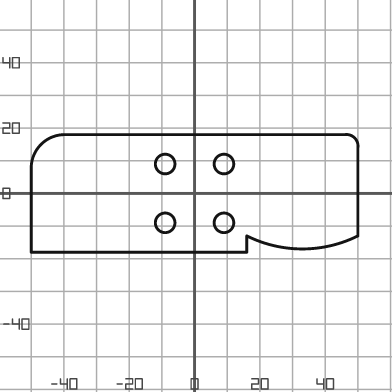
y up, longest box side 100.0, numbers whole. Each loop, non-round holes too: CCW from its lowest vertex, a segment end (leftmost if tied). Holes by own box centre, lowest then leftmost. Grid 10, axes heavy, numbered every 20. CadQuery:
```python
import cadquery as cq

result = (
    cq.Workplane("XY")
    .moveTo(-50.0, -18.0)
    .lineTo(16.0, -18.0)
    .lineTo(16.0, -13.0)
    .threePointArc((33.0, -17.0), (50.0, -13.0))
    .lineTo(50.0, 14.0)
    .threePointArc((49.0, 17.0), (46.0, 18.0))
    .lineTo(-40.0, 18.0)
    .threePointArc((-47.0, 15.0), (-50.0, 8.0))
    .close()
    .moveTo(-9.0, -9.0)
    .circle(3.0)
    .moveTo(9.0, -9.0)
    .circle(3.0)
    .moveTo(-9.0, 9.0)
    .circle(3.0)
    .moveTo(9.0, 9.0)
    .circle(3.0)
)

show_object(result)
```